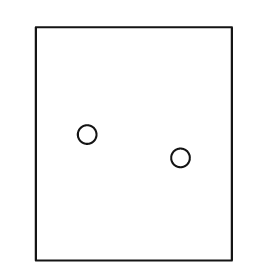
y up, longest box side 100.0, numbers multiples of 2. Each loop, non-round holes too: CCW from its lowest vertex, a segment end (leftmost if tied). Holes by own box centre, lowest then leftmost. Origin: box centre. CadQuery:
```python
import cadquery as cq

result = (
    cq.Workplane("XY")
    .moveTo(-42.0, -50.0)
    .lineTo(42.0, -50.0)
    .lineTo(42.0, 50.0)
    .lineTo(-42.0, 50.0)
    .close()
    .moveTo(20.0, -6.0)
    .circle(4.0)
    .moveTo(-20.0, 4.0)
    .circle(4.0)
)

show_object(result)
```